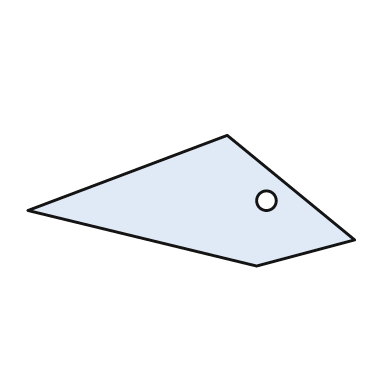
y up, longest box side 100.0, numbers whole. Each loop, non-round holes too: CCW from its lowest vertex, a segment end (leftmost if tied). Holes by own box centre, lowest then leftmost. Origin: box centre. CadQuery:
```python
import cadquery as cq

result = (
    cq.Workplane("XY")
    .moveTo(20.0, -20.0)
    .lineTo(50.0, -12.0)
    .lineTo(11.0, 20.0)
    .lineTo(-50.0, -3.0)
    .close()
    .moveTo(23.0, 0.0)
    .circle(3.0)
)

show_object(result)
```